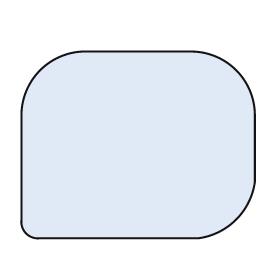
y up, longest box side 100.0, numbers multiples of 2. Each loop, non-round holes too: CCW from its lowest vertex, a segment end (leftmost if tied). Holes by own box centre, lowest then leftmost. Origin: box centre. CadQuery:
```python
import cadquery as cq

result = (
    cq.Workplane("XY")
    .moveTo(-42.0, -40.0)
    .lineTo(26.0, -40.0)
    .threePointArc((42.0, -32.0), (50.0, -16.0))
    .lineTo(50.0, 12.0)
    .threePointArc((42.0, 32.0), (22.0, 40.0))
    .lineTo(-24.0, 40.0)
    .threePointArc((-42.0, 32.0), (-50.0, 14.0))
    .lineTo(-50.0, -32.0)
    .threePointArc((-48.0, -38.0), (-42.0, -40.0))
    .close()
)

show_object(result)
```